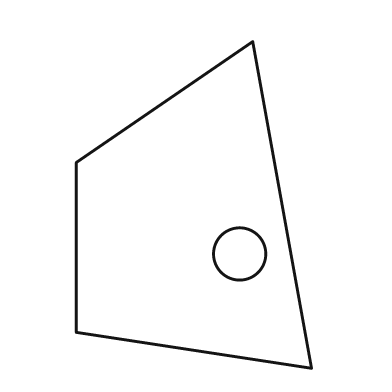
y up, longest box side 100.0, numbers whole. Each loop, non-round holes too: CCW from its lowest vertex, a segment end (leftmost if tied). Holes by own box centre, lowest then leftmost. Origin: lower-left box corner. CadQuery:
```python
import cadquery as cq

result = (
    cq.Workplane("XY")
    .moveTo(72.0, 0.0)
    .lineTo(54.0, 100.0)
    .lineTo(0.0, 63.0)
    .lineTo(0.0, 11.0)
    .close()
    .moveTo(50.0, 35.0)
    .circle(8.0)
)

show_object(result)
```